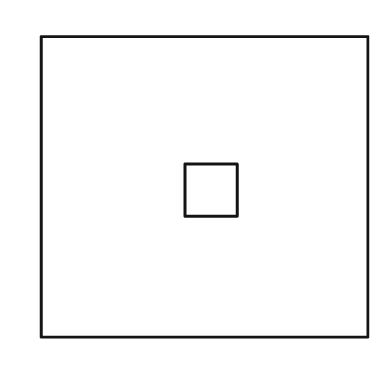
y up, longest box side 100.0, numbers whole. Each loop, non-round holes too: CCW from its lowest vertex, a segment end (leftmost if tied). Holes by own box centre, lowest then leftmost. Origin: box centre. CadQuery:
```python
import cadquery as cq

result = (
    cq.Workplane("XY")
    .moveTo(-50.0, -46.0)
    .lineTo(50.0, -46.0)
    .lineTo(50.0, 46.0)
    .lineTo(-50.0, 46.0)
    .close()
    .moveTo(-6.0, -9.0)
    .lineTo(10.0, -9.0)
    .lineTo(10.0, 7.0)
    .lineTo(-6.0, 7.0)
    .close()
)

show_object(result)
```